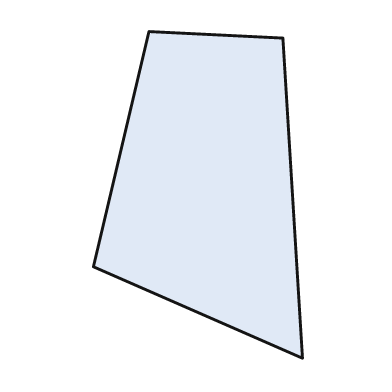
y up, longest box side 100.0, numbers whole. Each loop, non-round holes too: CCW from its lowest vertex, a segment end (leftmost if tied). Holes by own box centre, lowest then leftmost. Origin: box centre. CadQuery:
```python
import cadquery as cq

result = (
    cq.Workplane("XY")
    .moveTo(32.0, -50.0)
    .lineTo(26.0, 48.0)
    .lineTo(-15.0, 50.0)
    .lineTo(-32.0, -22.0)
    .close()
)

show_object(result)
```